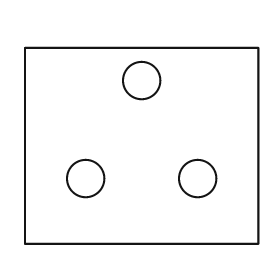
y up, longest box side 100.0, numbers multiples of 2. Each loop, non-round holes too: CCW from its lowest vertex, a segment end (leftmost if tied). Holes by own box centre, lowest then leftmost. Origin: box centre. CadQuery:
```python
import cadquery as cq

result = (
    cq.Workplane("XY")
    .moveTo(-50.0, -42.0)
    .lineTo(50.0, -42.0)
    .lineTo(50.0, 42.0)
    .lineTo(-50.0, 42.0)
    .close()
    .moveTo(-24.0, -14.0)
    .circle(8.0)
    .moveTo(24.0, -14.0)
    .circle(8.0)
    .moveTo(0.0, 28.0)
    .circle(8.0)
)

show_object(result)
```